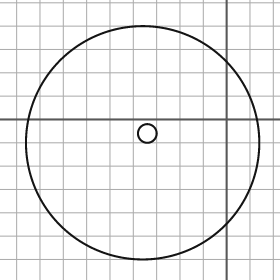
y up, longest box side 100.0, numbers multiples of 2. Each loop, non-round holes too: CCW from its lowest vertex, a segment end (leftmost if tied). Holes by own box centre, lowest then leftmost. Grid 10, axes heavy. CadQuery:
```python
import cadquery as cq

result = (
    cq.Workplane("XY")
    .moveTo(-36.0, -10.0)
    .circle(50.0)
    .moveTo(-34.0, -6.0)
    .circle(4.0)
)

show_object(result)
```